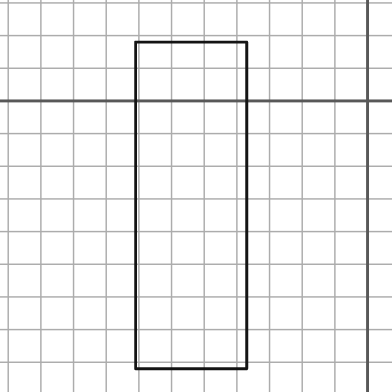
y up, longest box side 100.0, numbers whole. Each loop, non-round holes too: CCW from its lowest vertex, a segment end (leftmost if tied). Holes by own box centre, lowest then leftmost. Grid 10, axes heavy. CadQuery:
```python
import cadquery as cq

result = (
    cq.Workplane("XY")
    .moveTo(-71.0, -82.0)
    .lineTo(-37.0, -82.0)
    .lineTo(-37.0, 18.0)
    .lineTo(-71.0, 18.0)
    .close()
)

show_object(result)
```